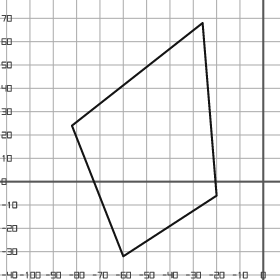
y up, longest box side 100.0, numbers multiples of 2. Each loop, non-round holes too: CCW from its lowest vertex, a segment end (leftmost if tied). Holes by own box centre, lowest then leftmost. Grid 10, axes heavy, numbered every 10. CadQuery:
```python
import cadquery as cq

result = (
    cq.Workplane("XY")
    .moveTo(-60.0, -32.0)
    .lineTo(-20.0, -6.0)
    .lineTo(-26.0, 68.0)
    .lineTo(-82.0, 24.0)
    .close()
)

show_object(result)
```